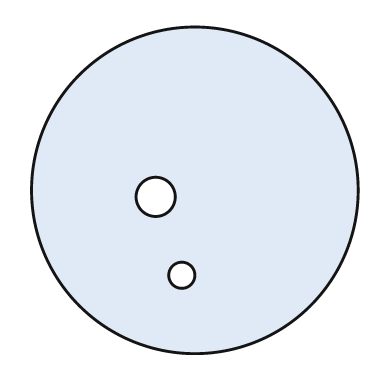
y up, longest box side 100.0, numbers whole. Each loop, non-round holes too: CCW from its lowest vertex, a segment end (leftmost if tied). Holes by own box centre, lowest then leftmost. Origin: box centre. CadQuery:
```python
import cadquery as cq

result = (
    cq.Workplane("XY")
    .moveTo(0.0, 0.0)
    .circle(50.0)
    .moveTo(-4.0, -26.0)
    .circle(4.0)
    .moveTo(-12.0, -2.0)
    .circle(6.0)
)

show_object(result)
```